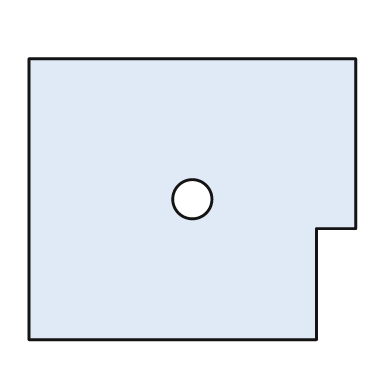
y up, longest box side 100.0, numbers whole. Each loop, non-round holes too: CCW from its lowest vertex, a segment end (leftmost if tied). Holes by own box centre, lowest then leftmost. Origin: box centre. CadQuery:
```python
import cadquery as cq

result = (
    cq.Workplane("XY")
    .moveTo(-50.0, -43.0)
    .lineTo(38.0, -43.0)
    .lineTo(38.0, -9.0)
    .lineTo(50.0, -9.0)
    .lineTo(50.0, 43.0)
    .lineTo(-50.0, 43.0)
    .close()
    .moveTo(0.0, 0.0)
    .circle(6.0)
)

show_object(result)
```